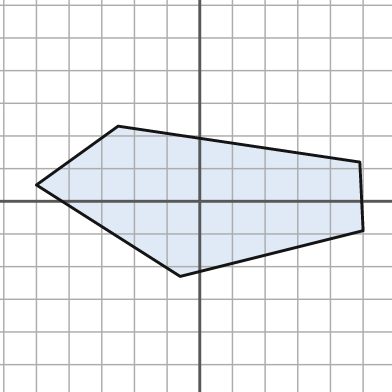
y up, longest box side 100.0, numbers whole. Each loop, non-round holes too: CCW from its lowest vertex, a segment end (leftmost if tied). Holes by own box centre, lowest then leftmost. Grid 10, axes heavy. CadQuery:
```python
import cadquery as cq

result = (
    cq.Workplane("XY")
    .moveTo(-6.0, -23.0)
    .lineTo(50.0, -9.0)
    .lineTo(49.0, 12.0)
    .lineTo(-25.0, 23.0)
    .lineTo(-50.0, 5.0)
    .close()
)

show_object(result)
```